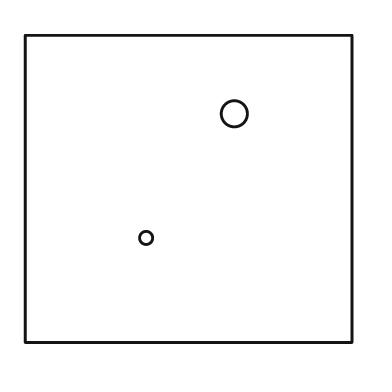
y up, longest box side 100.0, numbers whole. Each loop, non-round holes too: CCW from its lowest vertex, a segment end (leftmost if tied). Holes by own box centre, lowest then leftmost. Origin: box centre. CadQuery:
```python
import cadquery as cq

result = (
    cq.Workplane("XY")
    .moveTo(-50.0, -47.0)
    .lineTo(50.0, -47.0)
    .lineTo(50.0, 47.0)
    .lineTo(-50.0, 47.0)
    .close()
    .moveTo(-13.0, -15.0)
    .circle(2.0)
    .moveTo(14.0, 23.0)
    .circle(4.0)
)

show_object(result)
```